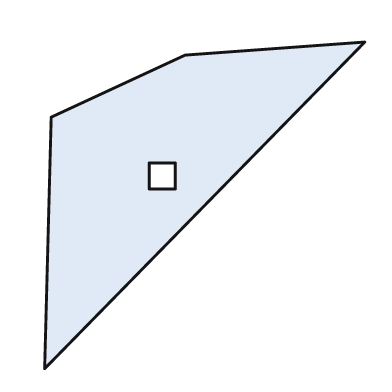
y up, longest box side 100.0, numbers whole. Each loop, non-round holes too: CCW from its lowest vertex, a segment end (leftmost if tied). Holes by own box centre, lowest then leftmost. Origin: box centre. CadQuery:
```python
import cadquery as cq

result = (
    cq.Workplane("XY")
    .moveTo(-49.0, -50.0)
    .lineTo(49.0, 50.0)
    .lineTo(-6.0, 46.0)
    .lineTo(-47.0, 27.0)
    .close()
    .moveTo(-17.0, 5.0)
    .lineTo(-9.0, 5.0)
    .lineTo(-9.0, 13.0)
    .lineTo(-17.0, 13.0)
    .close()
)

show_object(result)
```